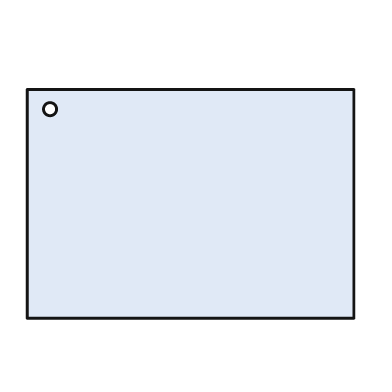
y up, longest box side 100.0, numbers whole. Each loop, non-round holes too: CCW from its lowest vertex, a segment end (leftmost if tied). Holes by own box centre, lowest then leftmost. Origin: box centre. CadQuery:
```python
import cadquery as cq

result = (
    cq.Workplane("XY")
    .moveTo(-50.0, -35.0)
    .lineTo(50.0, -35.0)
    .lineTo(50.0, 35.0)
    .lineTo(-50.0, 35.0)
    .close()
    .moveTo(-43.0, 29.0)
    .circle(2.0)
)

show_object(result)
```